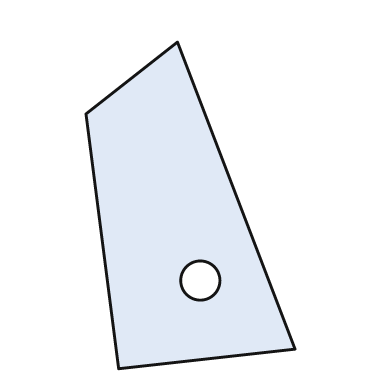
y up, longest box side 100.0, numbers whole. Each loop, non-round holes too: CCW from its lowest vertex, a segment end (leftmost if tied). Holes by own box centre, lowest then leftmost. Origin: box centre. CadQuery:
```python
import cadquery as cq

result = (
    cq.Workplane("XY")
    .moveTo(-22.0, -50.0)
    .lineTo(32.0, -44.0)
    .lineTo(-4.0, 50.0)
    .lineTo(-32.0, 28.0)
    .close()
    .moveTo(3.0, -23.0)
    .circle(6.0)
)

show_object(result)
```